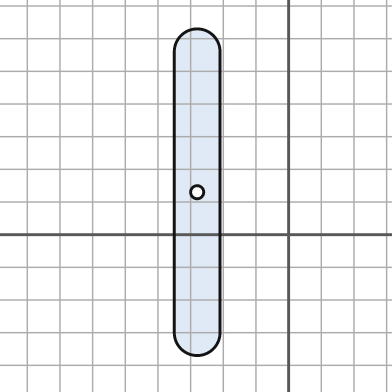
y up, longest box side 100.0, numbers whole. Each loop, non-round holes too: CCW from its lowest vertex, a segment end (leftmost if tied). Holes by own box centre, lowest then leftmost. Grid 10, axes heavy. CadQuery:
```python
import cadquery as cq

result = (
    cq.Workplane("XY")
    .moveTo(-35.0, -30.0)
    .threePointArc((-28.0, -37.0), (-21.0, -30.0))
    .lineTo(-21.0, 56.0)
    .threePointArc((-28.0, 63.0), (-35.0, 56.0))
    .close()
    .moveTo(-28.0, 13.0)
    .circle(2.0)
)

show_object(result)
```